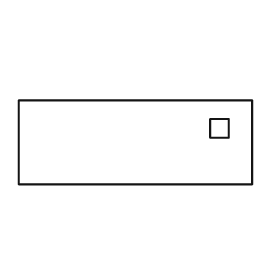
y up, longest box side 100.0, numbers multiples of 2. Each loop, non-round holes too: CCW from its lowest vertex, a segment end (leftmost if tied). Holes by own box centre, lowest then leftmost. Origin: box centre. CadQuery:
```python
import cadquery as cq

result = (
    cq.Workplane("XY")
    .moveTo(-50.0, -18.0)
    .lineTo(50.0, -18.0)
    .lineTo(50.0, 18.0)
    .lineTo(-50.0, 18.0)
    .close()
    .moveTo(32.0, 2.0)
    .lineTo(40.0, 2.0)
    .lineTo(40.0, 10.0)
    .lineTo(32.0, 10.0)
    .close()
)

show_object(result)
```